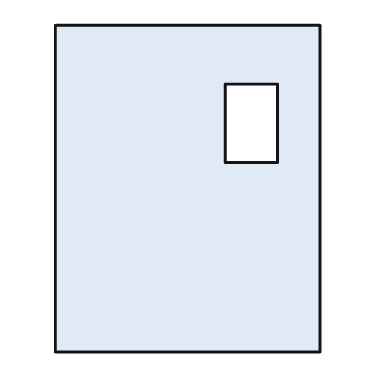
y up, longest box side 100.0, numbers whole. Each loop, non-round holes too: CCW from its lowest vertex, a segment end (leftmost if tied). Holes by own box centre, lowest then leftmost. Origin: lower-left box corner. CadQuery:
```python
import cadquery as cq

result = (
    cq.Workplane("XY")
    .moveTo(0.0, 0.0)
    .lineTo(81.0, 0.0)
    .lineTo(81.0, 100.0)
    .lineTo(0.0, 100.0)
    .close()
    .moveTo(52.0, 58.0)
    .lineTo(68.0, 58.0)
    .lineTo(68.0, 82.0)
    .lineTo(52.0, 82.0)
    .close()
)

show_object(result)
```